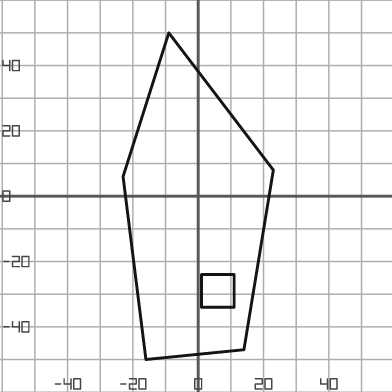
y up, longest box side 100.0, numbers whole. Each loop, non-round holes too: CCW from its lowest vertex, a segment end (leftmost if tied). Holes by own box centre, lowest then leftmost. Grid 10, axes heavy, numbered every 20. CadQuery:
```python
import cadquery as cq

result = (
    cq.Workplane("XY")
    .moveTo(-16.0, -50.0)
    .lineTo(14.0, -47.0)
    .lineTo(23.0, 8.0)
    .lineTo(-9.0, 50.0)
    .lineTo(-23.0, 6.0)
    .close()
    .moveTo(1.0, -34.0)
    .lineTo(11.0, -34.0)
    .lineTo(11.0, -24.0)
    .lineTo(1.0, -24.0)
    .close()
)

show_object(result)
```